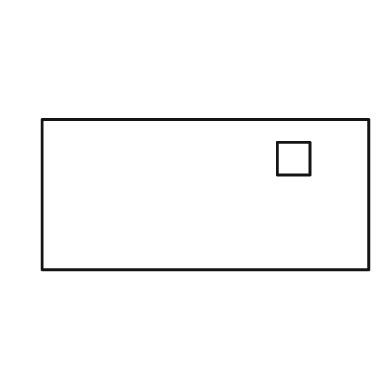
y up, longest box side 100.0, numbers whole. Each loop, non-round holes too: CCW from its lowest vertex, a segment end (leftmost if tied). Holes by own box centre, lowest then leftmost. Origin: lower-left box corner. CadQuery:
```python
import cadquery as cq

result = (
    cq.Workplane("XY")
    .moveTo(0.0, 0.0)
    .lineTo(100.0, 0.0)
    .lineTo(100.0, 46.0)
    .lineTo(0.0, 46.0)
    .close()
    .moveTo(72.0, 29.0)
    .lineTo(82.0, 29.0)
    .lineTo(82.0, 39.0)
    .lineTo(72.0, 39.0)
    .close()
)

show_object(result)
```